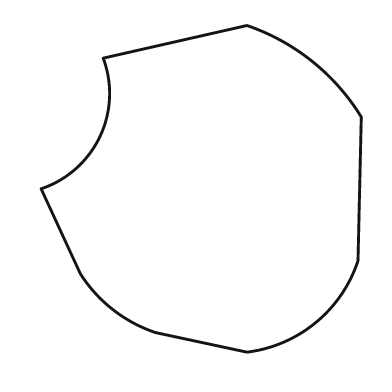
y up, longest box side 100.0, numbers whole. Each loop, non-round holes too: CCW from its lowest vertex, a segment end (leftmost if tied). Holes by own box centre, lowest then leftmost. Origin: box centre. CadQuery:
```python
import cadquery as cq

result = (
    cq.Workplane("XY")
    .moveTo(14.0, -50.0)
    .threePointArc((35.0, -41.0), (48.0, -22.0))
    .lineTo(49.0, 22.0)
    .threePointArc((34.0, 39.0), (14.0, 50.0))
    .lineTo(-30.0, 40.0)
    .threePointArc((-31.0, 16.0), (-49.0, 0.0))
    .lineTo(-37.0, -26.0)
    .threePointArc((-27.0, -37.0), (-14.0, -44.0))
    .close()
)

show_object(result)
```